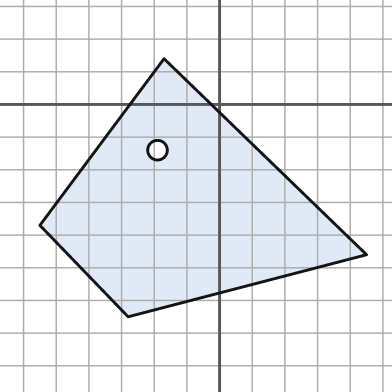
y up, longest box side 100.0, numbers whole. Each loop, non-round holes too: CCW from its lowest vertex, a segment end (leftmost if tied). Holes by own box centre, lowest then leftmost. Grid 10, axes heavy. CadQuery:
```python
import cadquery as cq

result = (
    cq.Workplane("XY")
    .moveTo(-28.0, -65.0)
    .lineTo(45.0, -46.0)
    .lineTo(-17.0, 14.0)
    .lineTo(-55.0, -37.0)
    .close()
    .moveTo(-19.0, -14.0)
    .circle(3.0)
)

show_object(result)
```